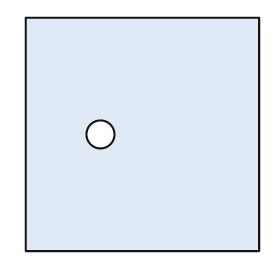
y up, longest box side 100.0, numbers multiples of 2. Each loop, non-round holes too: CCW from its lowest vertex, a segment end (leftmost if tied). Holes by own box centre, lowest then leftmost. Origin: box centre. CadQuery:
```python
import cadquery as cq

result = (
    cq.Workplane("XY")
    .moveTo(-50.0, -50.0)
    .lineTo(50.0, -50.0)
    .lineTo(50.0, 50.0)
    .lineTo(-50.0, 50.0)
    .close()
    .moveTo(-18.0, 0.0)
    .circle(6.0)
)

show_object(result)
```